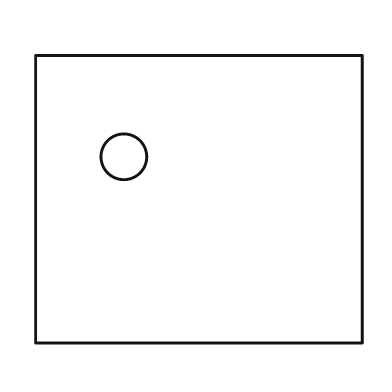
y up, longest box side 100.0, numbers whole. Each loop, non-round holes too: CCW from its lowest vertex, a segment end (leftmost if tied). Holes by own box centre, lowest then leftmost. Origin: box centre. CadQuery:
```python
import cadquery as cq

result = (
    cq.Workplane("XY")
    .moveTo(-50.0, -44.0)
    .lineTo(50.0, -44.0)
    .lineTo(50.0, 44.0)
    .lineTo(-50.0, 44.0)
    .close()
    .moveTo(-23.0, 13.0)
    .circle(7.0)
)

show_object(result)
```